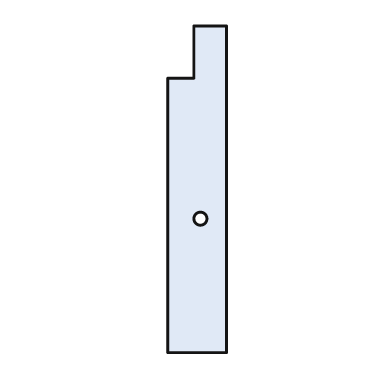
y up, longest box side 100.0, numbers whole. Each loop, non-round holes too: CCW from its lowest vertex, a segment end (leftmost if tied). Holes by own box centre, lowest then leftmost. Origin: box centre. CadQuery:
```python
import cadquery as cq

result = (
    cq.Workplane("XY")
    .moveTo(-9.0, -50.0)
    .lineTo(9.0, -50.0)
    .lineTo(9.0, 50.0)
    .lineTo(-1.0, 50.0)
    .lineTo(-1.0, 34.0)
    .lineTo(-9.0, 34.0)
    .close()
    .moveTo(1.0, -9.0)
    .circle(2.0)
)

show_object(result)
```